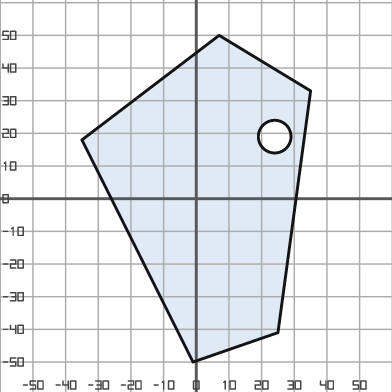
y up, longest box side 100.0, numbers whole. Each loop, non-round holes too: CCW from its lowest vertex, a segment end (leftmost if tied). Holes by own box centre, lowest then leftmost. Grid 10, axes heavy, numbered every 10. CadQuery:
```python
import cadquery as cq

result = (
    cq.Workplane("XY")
    .moveTo(-1.0, -50.0)
    .lineTo(25.0, -41.0)
    .lineTo(35.0, 33.0)
    .lineTo(7.0, 50.0)
    .lineTo(-35.0, 18.0)
    .close()
    .moveTo(24.0, 19.0)
    .circle(5.0)
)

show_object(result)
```